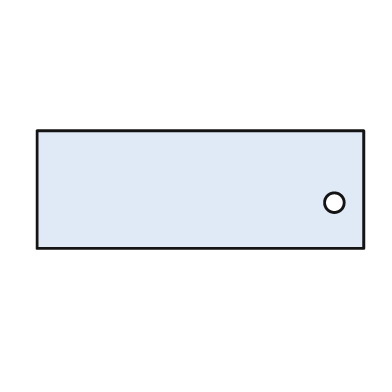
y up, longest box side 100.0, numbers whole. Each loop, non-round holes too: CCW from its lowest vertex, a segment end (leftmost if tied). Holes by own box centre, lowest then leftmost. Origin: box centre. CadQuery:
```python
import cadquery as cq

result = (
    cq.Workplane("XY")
    .moveTo(-50.0, -18.0)
    .lineTo(50.0, -18.0)
    .lineTo(50.0, 18.0)
    .lineTo(-50.0, 18.0)
    .close()
    .moveTo(41.0, -4.0)
    .circle(3.0)
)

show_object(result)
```